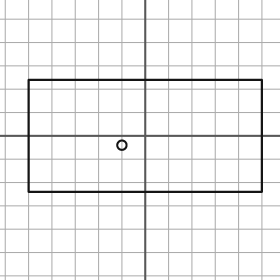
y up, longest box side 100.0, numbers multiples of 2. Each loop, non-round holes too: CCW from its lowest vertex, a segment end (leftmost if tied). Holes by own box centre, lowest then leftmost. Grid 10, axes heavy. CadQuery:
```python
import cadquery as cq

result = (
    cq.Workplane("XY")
    .moveTo(-50.0, -24.0)
    .lineTo(50.0, -24.0)
    .lineTo(50.0, 24.0)
    .lineTo(-50.0, 24.0)
    .close()
    .moveTo(-10.0, -4.0)
    .circle(2.0)
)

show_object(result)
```